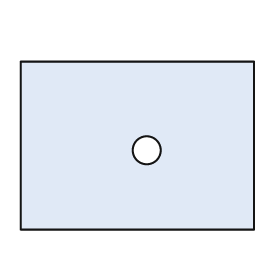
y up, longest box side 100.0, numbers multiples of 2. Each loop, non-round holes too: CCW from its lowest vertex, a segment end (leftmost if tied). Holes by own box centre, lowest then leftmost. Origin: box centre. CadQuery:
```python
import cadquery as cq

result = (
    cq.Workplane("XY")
    .moveTo(-50.0, -36.0)
    .lineTo(50.0, -36.0)
    .lineTo(50.0, 36.0)
    .lineTo(-50.0, 36.0)
    .close()
    .moveTo(4.0, -2.0)
    .circle(6.0)
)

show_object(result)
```